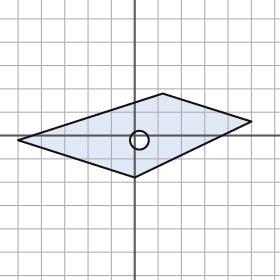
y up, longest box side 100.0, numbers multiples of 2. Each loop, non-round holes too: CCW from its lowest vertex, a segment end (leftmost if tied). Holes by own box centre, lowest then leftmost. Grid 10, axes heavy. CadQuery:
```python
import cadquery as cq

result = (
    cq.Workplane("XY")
    .moveTo(0.0, -18.0)
    .lineTo(50.0, 6.0)
    .lineTo(12.0, 18.0)
    .lineTo(-50.0, -2.0)
    .close()
    .moveTo(2.0, -2.0)
    .circle(4.0)
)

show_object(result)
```